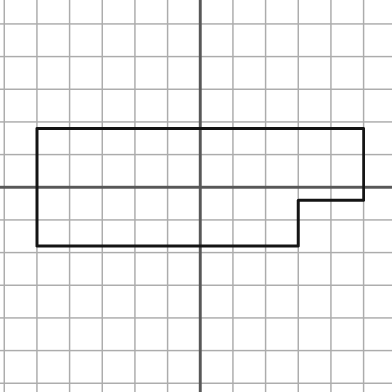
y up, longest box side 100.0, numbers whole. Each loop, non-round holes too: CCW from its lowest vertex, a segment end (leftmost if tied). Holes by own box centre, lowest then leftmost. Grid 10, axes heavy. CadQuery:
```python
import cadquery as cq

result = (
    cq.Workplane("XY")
    .moveTo(-50.0, -18.0)
    .lineTo(30.0, -18.0)
    .lineTo(30.0, -4.0)
    .lineTo(50.0, -4.0)
    .lineTo(50.0, 18.0)
    .lineTo(-50.0, 18.0)
    .close()
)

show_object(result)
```